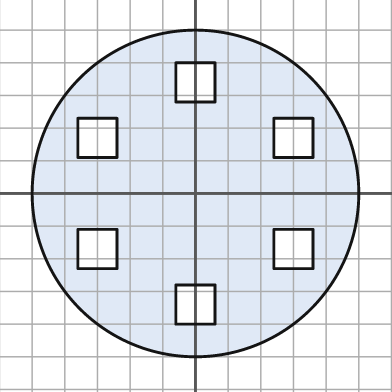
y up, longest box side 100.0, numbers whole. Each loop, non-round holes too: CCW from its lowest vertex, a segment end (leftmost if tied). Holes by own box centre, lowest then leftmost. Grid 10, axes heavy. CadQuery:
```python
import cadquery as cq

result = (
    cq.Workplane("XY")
    .moveTo(0.0, 0.0)
    .circle(50.0)
    .moveTo(-6.0, -40.0)
    .lineTo(6.0, -40.0)
    .lineTo(6.0, -28.0)
    .lineTo(-6.0, -28.0)
    .close()
    .moveTo(-36.0, -23.0)
    .lineTo(-24.0, -23.0)
    .lineTo(-24.0, -11.0)
    .lineTo(-36.0, -11.0)
    .close()
    .moveTo(24.0, -23.0)
    .lineTo(36.0, -23.0)
    .lineTo(36.0, -11.0)
    .lineTo(24.0, -11.0)
    .close()
    .moveTo(-36.0, 11.0)
    .lineTo(-24.0, 11.0)
    .lineTo(-24.0, 23.0)
    .lineTo(-36.0, 23.0)
    .close()
    .moveTo(24.0, 11.0)
    .lineTo(36.0, 11.0)
    .lineTo(36.0, 23.0)
    .lineTo(24.0, 23.0)
    .close()
    .moveTo(-6.0, 28.0)
    .lineTo(6.0, 28.0)
    .lineTo(6.0, 40.0)
    .lineTo(-6.0, 40.0)
    .close()
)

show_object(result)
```